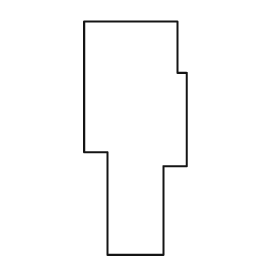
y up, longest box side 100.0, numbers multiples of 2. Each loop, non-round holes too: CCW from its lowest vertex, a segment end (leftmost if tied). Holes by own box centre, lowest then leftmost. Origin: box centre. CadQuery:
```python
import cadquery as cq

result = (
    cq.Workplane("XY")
    .moveTo(-12.0, -50.0)
    .lineTo(12.0, -50.0)
    .lineTo(12.0, -12.0)
    .lineTo(22.0, -12.0)
    .lineTo(22.0, 28.0)
    .lineTo(18.0, 28.0)
    .lineTo(18.0, 50.0)
    .lineTo(-22.0, 50.0)
    .lineTo(-22.0, -6.0)
    .lineTo(-12.0, -6.0)
    .close()
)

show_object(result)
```